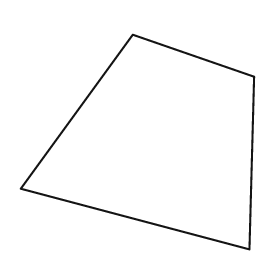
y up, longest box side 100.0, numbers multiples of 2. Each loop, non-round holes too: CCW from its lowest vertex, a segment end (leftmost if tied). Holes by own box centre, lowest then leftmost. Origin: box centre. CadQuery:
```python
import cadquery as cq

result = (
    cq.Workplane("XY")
    .moveTo(48.0, -46.0)
    .lineTo(50.0, 28.0)
    .lineTo(-2.0, 46.0)
    .lineTo(-50.0, -20.0)
    .close()
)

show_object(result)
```